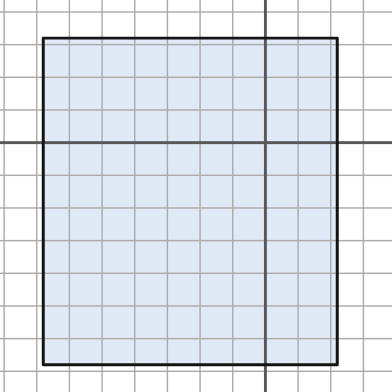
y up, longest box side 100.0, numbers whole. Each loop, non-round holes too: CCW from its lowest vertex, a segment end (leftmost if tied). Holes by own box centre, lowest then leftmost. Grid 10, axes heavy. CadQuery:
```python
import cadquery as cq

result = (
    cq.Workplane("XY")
    .moveTo(-68.0, -68.0)
    .lineTo(22.0, -68.0)
    .lineTo(22.0, 32.0)
    .lineTo(-68.0, 32.0)
    .close()
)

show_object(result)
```